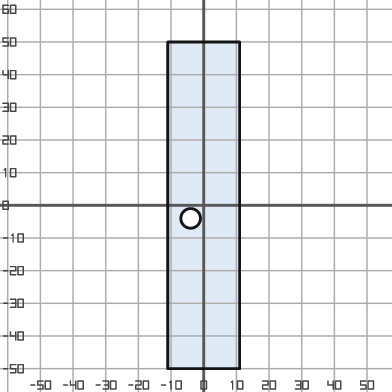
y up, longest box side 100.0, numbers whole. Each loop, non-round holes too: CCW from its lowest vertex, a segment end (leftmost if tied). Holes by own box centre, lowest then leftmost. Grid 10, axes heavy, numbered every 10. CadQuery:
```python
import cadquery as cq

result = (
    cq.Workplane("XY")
    .moveTo(-11.0, -50.0)
    .lineTo(11.0, -50.0)
    .lineTo(11.0, 50.0)
    .lineTo(-11.0, 50.0)
    .close()
    .moveTo(-4.0, -4.0)
    .circle(3.0)
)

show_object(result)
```